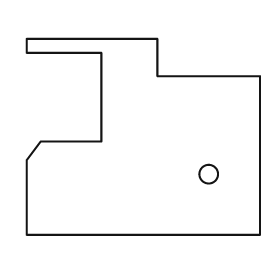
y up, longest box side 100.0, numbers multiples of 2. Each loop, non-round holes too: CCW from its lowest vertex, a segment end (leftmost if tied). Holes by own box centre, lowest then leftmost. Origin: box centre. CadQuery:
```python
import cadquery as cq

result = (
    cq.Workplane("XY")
    .moveTo(-50.0, -42.0)
    .lineTo(50.0, -42.0)
    .lineTo(50.0, 26.0)
    .lineTo(6.0, 26.0)
    .lineTo(6.0, 42.0)
    .lineTo(-50.0, 42.0)
    .lineTo(-50.0, 36.0)
    .lineTo(-18.0, 36.0)
    .lineTo(-18.0, -2.0)
    .lineTo(-44.0, -2.0)
    .lineTo(-50.0, -10.0)
    .close()
    .moveTo(28.0, -16.0)
    .circle(4.0)
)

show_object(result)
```